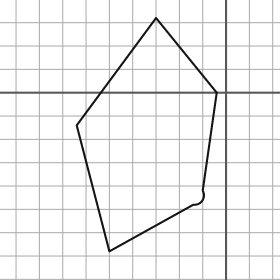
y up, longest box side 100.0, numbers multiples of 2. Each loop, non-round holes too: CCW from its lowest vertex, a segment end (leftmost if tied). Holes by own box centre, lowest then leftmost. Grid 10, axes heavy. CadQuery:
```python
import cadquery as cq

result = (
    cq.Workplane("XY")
    .moveTo(-50.0, -68.0)
    .lineTo(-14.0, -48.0)
    .threePointArc((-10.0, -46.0), (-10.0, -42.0))
    .lineTo(-4.0, 0.0)
    .lineTo(-30.0, 32.0)
    .lineTo(-64.0, -14.0)
    .close()
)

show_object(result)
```